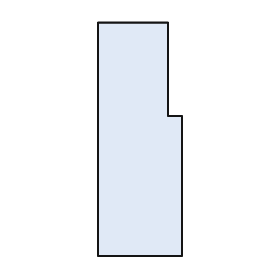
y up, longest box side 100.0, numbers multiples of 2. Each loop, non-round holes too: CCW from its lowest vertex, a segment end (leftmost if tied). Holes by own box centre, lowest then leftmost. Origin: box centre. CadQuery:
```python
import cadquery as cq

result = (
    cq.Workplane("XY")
    .moveTo(-18.0, -50.0)
    .lineTo(18.0, -50.0)
    .lineTo(18.0, 10.0)
    .lineTo(12.0, 10.0)
    .lineTo(12.0, 50.0)
    .lineTo(-18.0, 50.0)
    .close()
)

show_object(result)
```